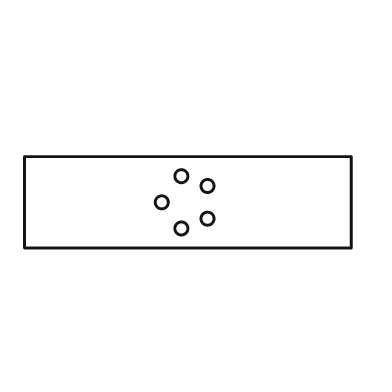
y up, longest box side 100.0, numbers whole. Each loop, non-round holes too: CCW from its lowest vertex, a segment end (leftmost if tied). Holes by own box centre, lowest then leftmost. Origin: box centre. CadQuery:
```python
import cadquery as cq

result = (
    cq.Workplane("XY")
    .moveTo(-50.0, -14.0)
    .lineTo(50.0, -14.0)
    .lineTo(50.0, 14.0)
    .lineTo(-50.0, 14.0)
    .close()
    .moveTo(-2.0, -8.0)
    .circle(2.0)
    .moveTo(6.0, -5.0)
    .circle(2.0)
    .moveTo(-8.0, 0.0)
    .circle(2.0)
    .moveTo(6.0, 5.0)
    .circle(2.0)
    .moveTo(-2.0, 8.0)
    .circle(2.0)
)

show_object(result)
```